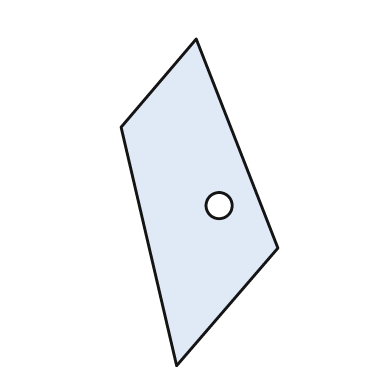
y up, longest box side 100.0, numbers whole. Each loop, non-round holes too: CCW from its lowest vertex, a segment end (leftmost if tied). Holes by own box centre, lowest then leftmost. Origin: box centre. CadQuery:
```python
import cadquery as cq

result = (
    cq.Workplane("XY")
    .moveTo(-7.0, -50.0)
    .lineTo(24.0, -14.0)
    .lineTo(-1.0, 50.0)
    .lineTo(-24.0, 23.0)
    .close()
    .moveTo(6.0, -1.0)
    .circle(4.0)
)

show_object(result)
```